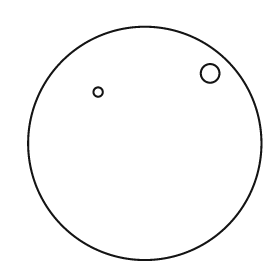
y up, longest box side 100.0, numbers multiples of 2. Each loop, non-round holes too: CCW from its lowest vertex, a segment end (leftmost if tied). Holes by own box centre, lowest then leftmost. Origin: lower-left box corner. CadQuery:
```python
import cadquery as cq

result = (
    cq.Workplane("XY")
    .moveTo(50.0, 50.0)
    .circle(50.0)
    .moveTo(30.0, 72.0)
    .circle(2.0)
    .moveTo(78.0, 80.0)
    .circle(4.0)
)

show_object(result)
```